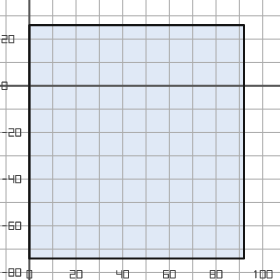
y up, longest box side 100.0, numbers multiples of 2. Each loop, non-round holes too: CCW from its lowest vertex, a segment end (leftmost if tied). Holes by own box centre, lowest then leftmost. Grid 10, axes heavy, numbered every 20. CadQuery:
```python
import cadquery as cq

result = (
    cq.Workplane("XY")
    .moveTo(0.0, -74.0)
    .lineTo(92.0, -74.0)
    .lineTo(92.0, 26.0)
    .lineTo(0.0, 26.0)
    .close()
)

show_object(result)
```